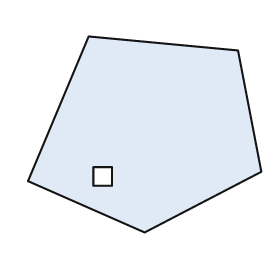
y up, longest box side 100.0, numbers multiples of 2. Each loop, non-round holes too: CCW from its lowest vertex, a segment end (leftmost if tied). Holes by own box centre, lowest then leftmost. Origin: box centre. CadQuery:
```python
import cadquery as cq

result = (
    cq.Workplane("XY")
    .moveTo(0.0, -42.0)
    .lineTo(50.0, -16.0)
    .lineTo(40.0, 36.0)
    .lineTo(-24.0, 42.0)
    .lineTo(-50.0, -20.0)
    .close()
    .moveTo(-22.0, -22.0)
    .lineTo(-14.0, -22.0)
    .lineTo(-14.0, -14.0)
    .lineTo(-22.0, -14.0)
    .close()
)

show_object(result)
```